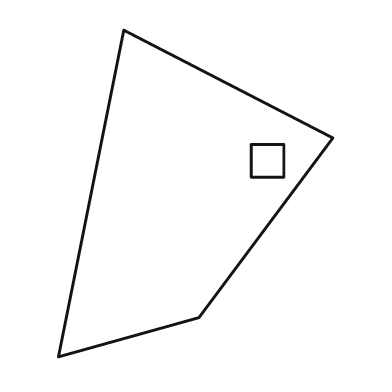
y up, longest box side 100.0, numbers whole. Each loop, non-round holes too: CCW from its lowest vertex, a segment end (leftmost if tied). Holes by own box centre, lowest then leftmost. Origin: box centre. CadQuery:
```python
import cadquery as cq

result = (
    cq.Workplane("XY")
    .moveTo(-42.0, -50.0)
    .lineTo(1.0, -38.0)
    .lineTo(42.0, 17.0)
    .lineTo(-22.0, 50.0)
    .close()
    .moveTo(17.0, 5.0)
    .lineTo(27.0, 5.0)
    .lineTo(27.0, 15.0)
    .lineTo(17.0, 15.0)
    .close()
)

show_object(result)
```